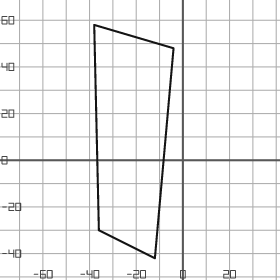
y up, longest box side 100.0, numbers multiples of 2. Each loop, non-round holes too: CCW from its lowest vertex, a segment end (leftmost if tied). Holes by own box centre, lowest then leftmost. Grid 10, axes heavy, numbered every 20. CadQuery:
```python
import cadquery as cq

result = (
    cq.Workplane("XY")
    .moveTo(-12.0, -42.0)
    .lineTo(-4.0, 48.0)
    .lineTo(-38.0, 58.0)
    .lineTo(-36.0, -30.0)
    .close()
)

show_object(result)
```